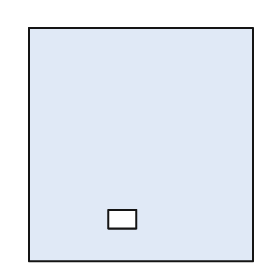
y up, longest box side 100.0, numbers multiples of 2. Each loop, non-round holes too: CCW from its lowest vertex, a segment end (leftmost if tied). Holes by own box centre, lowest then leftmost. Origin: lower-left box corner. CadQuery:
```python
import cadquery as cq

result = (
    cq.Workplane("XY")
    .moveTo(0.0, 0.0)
    .lineTo(96.0, 0.0)
    .lineTo(96.0, 100.0)
    .lineTo(0.0, 100.0)
    .close()
    .moveTo(34.0, 14.0)
    .lineTo(46.0, 14.0)
    .lineTo(46.0, 22.0)
    .lineTo(34.0, 22.0)
    .close()
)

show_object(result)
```